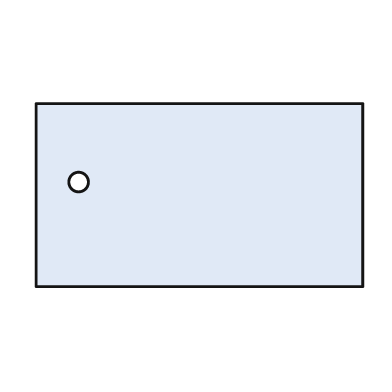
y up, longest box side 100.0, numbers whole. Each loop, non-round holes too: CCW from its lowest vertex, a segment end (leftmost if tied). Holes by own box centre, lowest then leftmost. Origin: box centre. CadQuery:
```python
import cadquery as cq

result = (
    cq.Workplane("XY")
    .moveTo(-50.0, -28.0)
    .lineTo(50.0, -28.0)
    .lineTo(50.0, 28.0)
    .lineTo(-50.0, 28.0)
    .close()
    .moveTo(-37.0, 4.0)
    .circle(3.0)
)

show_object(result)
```